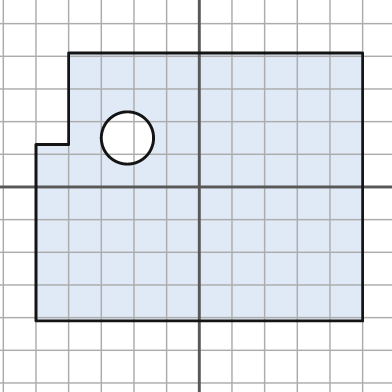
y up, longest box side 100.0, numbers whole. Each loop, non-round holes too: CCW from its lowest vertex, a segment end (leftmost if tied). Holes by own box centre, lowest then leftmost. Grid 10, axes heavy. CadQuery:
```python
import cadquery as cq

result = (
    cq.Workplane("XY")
    .moveTo(-50.0, -41.0)
    .lineTo(50.0, -41.0)
    .lineTo(50.0, 41.0)
    .lineTo(-40.0, 41.0)
    .lineTo(-40.0, 13.0)
    .lineTo(-50.0, 13.0)
    .close()
    .moveTo(-22.0, 15.0)
    .circle(8.0)
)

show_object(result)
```